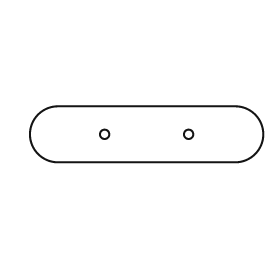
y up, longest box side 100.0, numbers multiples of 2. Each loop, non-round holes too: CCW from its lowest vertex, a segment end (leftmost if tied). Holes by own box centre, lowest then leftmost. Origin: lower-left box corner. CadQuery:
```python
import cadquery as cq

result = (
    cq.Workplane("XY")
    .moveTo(12.0, 0.0)
    .lineTo(88.0, 0.0)
    .threePointArc((100.0, 12.0), (88.0, 24.0))
    .lineTo(12.0, 24.0)
    .threePointArc((0.0, 12.0), (12.0, 0.0))
    .close()
    .moveTo(32.0, 12.0)
    .circle(2.0)
    .moveTo(68.0, 12.0)
    .circle(2.0)
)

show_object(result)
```